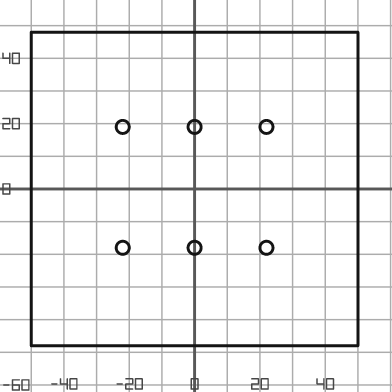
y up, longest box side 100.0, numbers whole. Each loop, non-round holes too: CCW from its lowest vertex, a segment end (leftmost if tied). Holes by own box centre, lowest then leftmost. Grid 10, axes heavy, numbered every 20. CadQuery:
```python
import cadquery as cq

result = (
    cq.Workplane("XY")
    .moveTo(-50.0, -48.0)
    .lineTo(50.0, -48.0)
    .lineTo(50.0, 48.0)
    .lineTo(-50.0, 48.0)
    .close()
    .moveTo(-22.0, -18.0)
    .circle(2.0)
    .moveTo(0.0, -18.0)
    .circle(2.0)
    .moveTo(22.0, -18.0)
    .circle(2.0)
    .moveTo(-22.0, 19.0)
    .circle(2.0)
    .moveTo(0.0, 19.0)
    .circle(2.0)
    .moveTo(22.0, 19.0)
    .circle(2.0)
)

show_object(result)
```